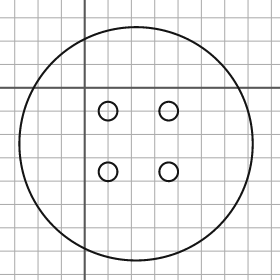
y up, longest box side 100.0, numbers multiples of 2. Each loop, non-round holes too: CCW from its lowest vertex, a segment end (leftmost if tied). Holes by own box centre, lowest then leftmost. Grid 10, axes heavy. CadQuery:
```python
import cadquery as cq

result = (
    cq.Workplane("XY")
    .moveTo(22.0, -24.0)
    .circle(50.0)
    .moveTo(10.0, -36.0)
    .circle(4.0)
    .moveTo(36.0, -36.0)
    .circle(4.0)
    .moveTo(10.0, -10.0)
    .circle(4.0)
    .moveTo(36.0, -10.0)
    .circle(4.0)
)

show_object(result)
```